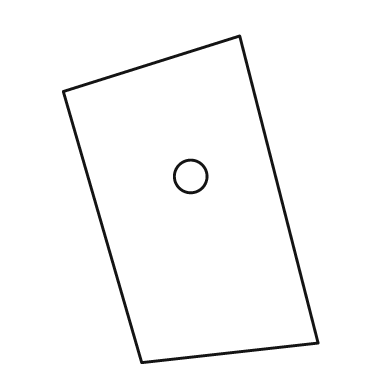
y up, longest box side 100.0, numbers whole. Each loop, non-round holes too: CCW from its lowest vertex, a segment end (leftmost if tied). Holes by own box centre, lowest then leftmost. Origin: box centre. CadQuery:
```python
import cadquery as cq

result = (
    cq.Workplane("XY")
    .moveTo(-15.0, -50.0)
    .lineTo(39.0, -44.0)
    .lineTo(15.0, 50.0)
    .lineTo(-39.0, 33.0)
    .close()
    .moveTo(0.0, 7.0)
    .circle(5.0)
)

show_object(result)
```